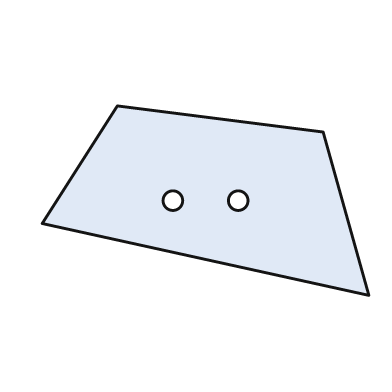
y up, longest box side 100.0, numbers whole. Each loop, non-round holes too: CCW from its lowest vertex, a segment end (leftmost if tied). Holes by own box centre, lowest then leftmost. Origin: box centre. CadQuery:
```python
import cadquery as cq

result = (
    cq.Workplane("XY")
    .moveTo(50.0, -29.0)
    .lineTo(36.0, 21.0)
    .lineTo(-27.0, 29.0)
    .lineTo(-50.0, -7.0)
    .close()
    .moveTo(-10.0, 0.0)
    .circle(3.0)
    .moveTo(10.0, 0.0)
    .circle(3.0)
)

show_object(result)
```